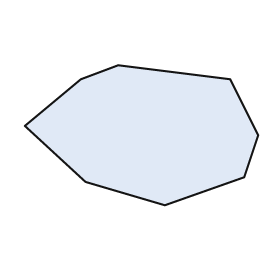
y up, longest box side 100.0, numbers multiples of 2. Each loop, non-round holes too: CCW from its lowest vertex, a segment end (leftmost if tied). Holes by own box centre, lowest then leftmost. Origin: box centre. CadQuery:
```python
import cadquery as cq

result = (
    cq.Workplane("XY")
    .moveTo(10.0, -30.0)
    .lineTo(44.0, -18.0)
    .lineTo(50.0, 0.0)
    .lineTo(38.0, 24.0)
    .lineTo(-10.0, 30.0)
    .lineTo(-26.0, 24.0)
    .lineTo(-50.0, 4.0)
    .lineTo(-24.0, -20.0)
    .close()
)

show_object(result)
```